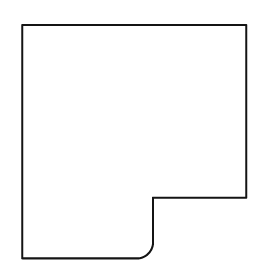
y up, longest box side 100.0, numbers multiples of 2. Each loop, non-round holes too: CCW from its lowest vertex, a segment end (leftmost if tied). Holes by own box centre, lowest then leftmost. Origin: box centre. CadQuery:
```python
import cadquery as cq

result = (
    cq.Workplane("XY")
    .moveTo(-48.0, -50.0)
    .lineTo(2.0, -50.0)
    .threePointArc((6.0, -48.0), (8.0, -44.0))
    .lineTo(8.0, -24.0)
    .lineTo(48.0, -24.0)
    .lineTo(48.0, 50.0)
    .lineTo(-48.0, 50.0)
    .close()
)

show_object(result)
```